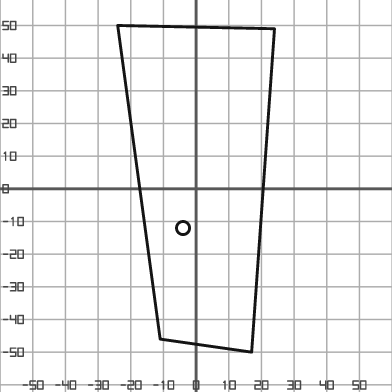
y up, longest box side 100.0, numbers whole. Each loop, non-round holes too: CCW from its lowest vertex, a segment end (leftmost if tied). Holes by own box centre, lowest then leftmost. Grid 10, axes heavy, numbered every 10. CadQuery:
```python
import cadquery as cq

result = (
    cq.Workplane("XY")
    .moveTo(17.0, -50.0)
    .lineTo(24.0, 49.0)
    .lineTo(-24.0, 50.0)
    .lineTo(-11.0, -46.0)
    .close()
    .moveTo(-4.0, -12.0)
    .circle(2.0)
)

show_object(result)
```